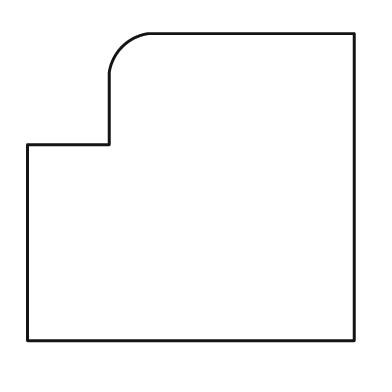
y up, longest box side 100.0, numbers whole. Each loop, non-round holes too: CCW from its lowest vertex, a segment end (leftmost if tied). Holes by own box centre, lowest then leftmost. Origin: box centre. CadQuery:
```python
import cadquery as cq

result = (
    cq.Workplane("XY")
    .moveTo(-50.0, -47.0)
    .lineTo(50.0, -47.0)
    .lineTo(50.0, 47.0)
    .lineTo(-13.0, 47.0)
    .threePointArc((-21.0, 43.0), (-25.0, 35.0))
    .lineTo(-25.0, 13.0)
    .lineTo(-50.0, 13.0)
    .close()
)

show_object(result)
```